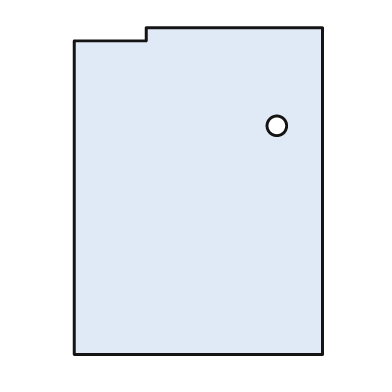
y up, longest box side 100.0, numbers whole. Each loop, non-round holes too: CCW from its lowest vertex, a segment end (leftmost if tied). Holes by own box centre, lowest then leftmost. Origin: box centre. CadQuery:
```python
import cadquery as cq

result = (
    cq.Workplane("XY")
    .moveTo(-38.0, -50.0)
    .lineTo(38.0, -50.0)
    .lineTo(38.0, 50.0)
    .lineTo(-16.0, 50.0)
    .lineTo(-16.0, 46.0)
    .lineTo(-38.0, 46.0)
    .close()
    .moveTo(24.0, 20.0)
    .circle(3.0)
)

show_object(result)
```